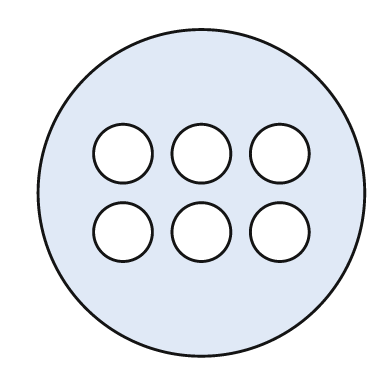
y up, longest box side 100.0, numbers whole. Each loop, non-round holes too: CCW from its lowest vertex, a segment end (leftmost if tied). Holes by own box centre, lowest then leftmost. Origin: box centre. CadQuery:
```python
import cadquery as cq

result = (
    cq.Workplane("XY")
    .moveTo(0.0, 0.0)
    .circle(50.0)
    .moveTo(-24.0, -12.0)
    .circle(9.0)
    .moveTo(0.0, -12.0)
    .circle(9.0)
    .moveTo(24.0, -12.0)
    .circle(9.0)
    .moveTo(-24.0, 12.0)
    .circle(9.0)
    .moveTo(0.0, 12.0)
    .circle(9.0)
    .moveTo(24.0, 12.0)
    .circle(9.0)
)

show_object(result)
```